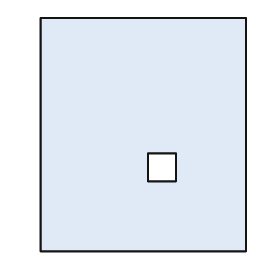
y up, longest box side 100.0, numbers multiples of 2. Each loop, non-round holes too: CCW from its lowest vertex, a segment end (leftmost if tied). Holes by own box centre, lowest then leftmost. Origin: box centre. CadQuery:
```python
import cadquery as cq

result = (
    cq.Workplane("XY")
    .moveTo(-44.0, -50.0)
    .lineTo(44.0, -50.0)
    .lineTo(44.0, 50.0)
    .lineTo(-44.0, 50.0)
    .close()
    .moveTo(2.0, -20.0)
    .lineTo(14.0, -20.0)
    .lineTo(14.0, -8.0)
    .lineTo(2.0, -8.0)
    .close()
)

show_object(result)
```